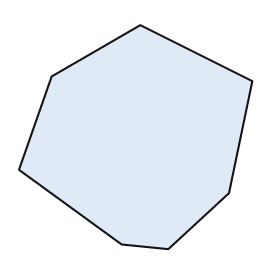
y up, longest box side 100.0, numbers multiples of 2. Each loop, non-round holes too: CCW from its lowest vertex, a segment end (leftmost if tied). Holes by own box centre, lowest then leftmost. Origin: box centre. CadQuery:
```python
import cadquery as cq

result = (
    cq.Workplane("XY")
    .moveTo(14.0, -48.0)
    .lineTo(40.0, -24.0)
    .lineTo(50.0, 24.0)
    .lineTo(2.0, 48.0)
    .lineTo(-36.0, 26.0)
    .lineTo(-50.0, -14.0)
    .lineTo(-6.0, -46.0)
    .close()
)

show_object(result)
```